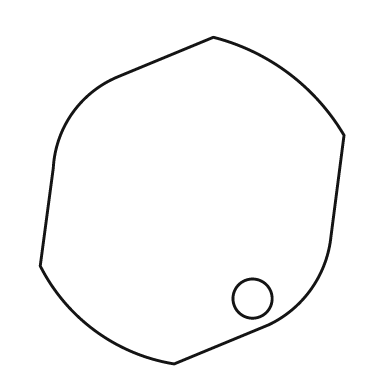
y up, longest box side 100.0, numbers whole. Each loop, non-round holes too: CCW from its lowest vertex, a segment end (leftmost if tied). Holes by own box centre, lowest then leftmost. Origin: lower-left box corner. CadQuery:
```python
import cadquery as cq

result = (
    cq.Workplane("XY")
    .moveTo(41.0, 0.0)
    .lineTo(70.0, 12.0)
    .threePointArc((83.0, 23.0), (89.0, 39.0))
    .lineTo(93.0, 70.0)
    .threePointArc((76.0, 89.0), (53.0, 100.0))
    .lineTo(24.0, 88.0)
    .threePointArc((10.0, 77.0), (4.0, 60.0))
    .lineTo(0.0, 30.0)
    .threePointArc((17.0, 10.0), (41.0, 0.0))
    .close()
    .moveTo(65.0, 20.0)
    .circle(6.0)
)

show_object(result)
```